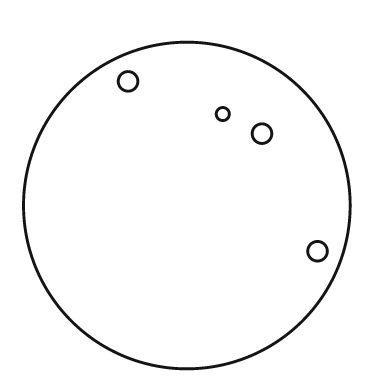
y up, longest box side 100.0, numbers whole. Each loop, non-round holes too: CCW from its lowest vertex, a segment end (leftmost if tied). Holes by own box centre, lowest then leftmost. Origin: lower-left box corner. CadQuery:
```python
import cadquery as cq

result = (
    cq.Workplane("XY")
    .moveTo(50.0, 50.0)
    .circle(50.0)
    .moveTo(90.0, 36.0)
    .circle(3.0)
    .moveTo(73.0, 72.0)
    .circle(3.0)
    .moveTo(61.0, 78.0)
    .circle(2.0)
    .moveTo(32.0, 88.0)
    .circle(3.0)
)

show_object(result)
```